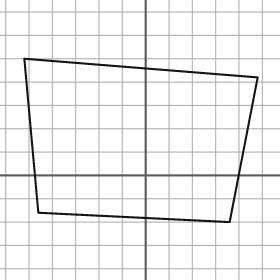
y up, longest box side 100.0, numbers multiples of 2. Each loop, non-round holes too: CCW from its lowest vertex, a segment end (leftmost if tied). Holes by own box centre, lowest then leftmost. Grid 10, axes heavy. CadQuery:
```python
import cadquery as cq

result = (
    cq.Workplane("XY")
    .moveTo(36.0, -20.0)
    .lineTo(48.0, 42.0)
    .lineTo(-52.0, 50.0)
    .lineTo(-46.0, -16.0)
    .close()
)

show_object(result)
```